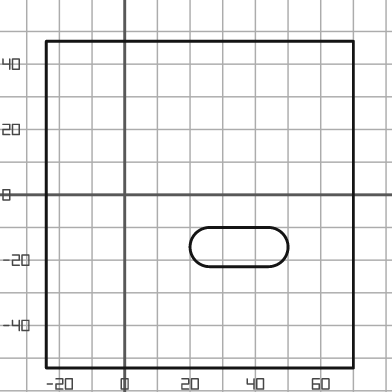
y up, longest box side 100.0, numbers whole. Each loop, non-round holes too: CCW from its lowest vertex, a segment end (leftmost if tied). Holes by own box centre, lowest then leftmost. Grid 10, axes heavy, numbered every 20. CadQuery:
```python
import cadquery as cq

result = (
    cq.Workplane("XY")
    .moveTo(-24.0, -53.0)
    .lineTo(70.0, -53.0)
    .lineTo(70.0, 47.0)
    .lineTo(-24.0, 47.0)
    .close()
    .moveTo(26.0, -22.0)
    .lineTo(44.0, -22.0)
    .threePointArc((50.0, -16.0), (44.0, -10.0))
    .lineTo(26.0, -10.0)
    .threePointArc((20.0, -16.0), (26.0, -22.0))
    .close()
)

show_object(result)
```